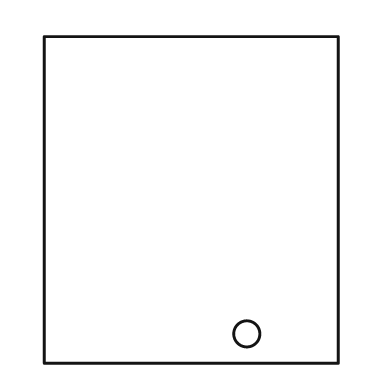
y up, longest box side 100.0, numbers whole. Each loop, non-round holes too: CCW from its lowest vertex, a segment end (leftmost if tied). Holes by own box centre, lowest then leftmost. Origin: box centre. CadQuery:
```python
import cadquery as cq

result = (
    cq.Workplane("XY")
    .moveTo(-45.0, -50.0)
    .lineTo(45.0, -50.0)
    .lineTo(45.0, 50.0)
    .lineTo(-45.0, 50.0)
    .close()
    .moveTo(17.0, -41.0)
    .circle(4.0)
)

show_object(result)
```